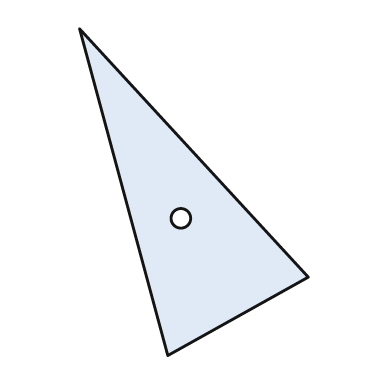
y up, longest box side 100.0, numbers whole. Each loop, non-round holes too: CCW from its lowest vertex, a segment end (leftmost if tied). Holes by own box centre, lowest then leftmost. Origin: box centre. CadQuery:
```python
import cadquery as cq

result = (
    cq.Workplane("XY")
    .moveTo(-8.0, -50.0)
    .lineTo(35.0, -26.0)
    .lineTo(-35.0, 50.0)
    .close()
    .moveTo(-4.0, -8.0)
    .circle(3.0)
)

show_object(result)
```